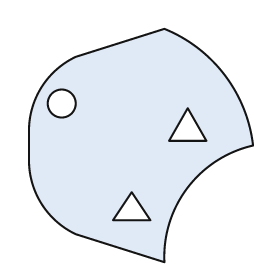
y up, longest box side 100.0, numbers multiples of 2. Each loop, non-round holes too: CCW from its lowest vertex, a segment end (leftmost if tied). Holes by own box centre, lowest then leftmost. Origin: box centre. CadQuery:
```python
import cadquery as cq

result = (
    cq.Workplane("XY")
    .moveTo(10.0, -50.0)
    .threePointArc((20.0, -18.0), (48.0, 0.0))
    .threePointArc((36.0, 30.0), (10.0, 50.0))
    .lineTo(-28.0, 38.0)
    .threePointArc((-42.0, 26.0), (-48.0, 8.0))
    .lineTo(-48.0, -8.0)
    .threePointArc((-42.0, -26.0), (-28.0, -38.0))
    .close()
    .moveTo(-12.0, -32.0)
    .lineTo(4.0, -32.0)
    .lineTo(-4.0, -20.0)
    .close()
    .moveTo(12.0, 2.0)
    .lineTo(28.0, 2.0)
    .lineTo(20.0, 16.0)
    .close()
    .moveTo(-34.0, 18.0)
    .circle(6.0)
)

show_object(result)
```